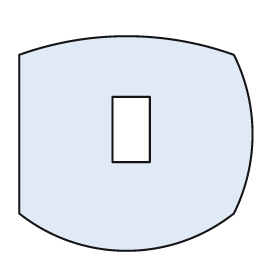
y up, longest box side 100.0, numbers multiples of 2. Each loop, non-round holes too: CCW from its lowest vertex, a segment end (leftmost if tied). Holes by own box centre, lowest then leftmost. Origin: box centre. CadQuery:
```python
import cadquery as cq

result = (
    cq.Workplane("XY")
    .moveTo(-50.0, -30.0)
    .threePointArc((-4.0, -46.0), (42.0, -30.0))
    .threePointArc((50.0, 4.0), (42.0, 38.0))
    .threePointArc((-4.0, 46.0), (-50.0, 38.0))
    .close()
    .moveTo(-10.0, -8.0)
    .lineTo(6.0, -8.0)
    .lineTo(6.0, 20.0)
    .lineTo(-10.0, 20.0)
    .close()
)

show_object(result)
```